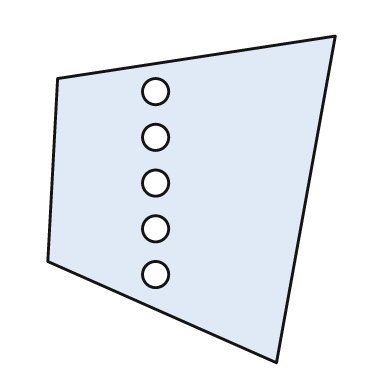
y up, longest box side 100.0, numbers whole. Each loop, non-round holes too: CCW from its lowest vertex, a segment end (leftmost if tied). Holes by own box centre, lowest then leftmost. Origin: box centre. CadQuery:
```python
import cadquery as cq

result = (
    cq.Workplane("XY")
    .moveTo(26.0, -50.0)
    .lineTo(44.0, 50.0)
    .lineTo(-41.0, 37.0)
    .lineTo(-44.0, -19.0)
    .close()
    .moveTo(-11.0, -23.0)
    .circle(4.0)
    .moveTo(-11.0, -9.0)
    .circle(4.0)
    .moveTo(-11.0, 5.0)
    .circle(4.0)
    .moveTo(-11.0, 19.0)
    .circle(4.0)
    .moveTo(-11.0, 33.0)
    .circle(4.0)
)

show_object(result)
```